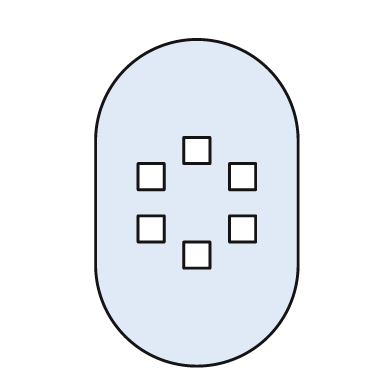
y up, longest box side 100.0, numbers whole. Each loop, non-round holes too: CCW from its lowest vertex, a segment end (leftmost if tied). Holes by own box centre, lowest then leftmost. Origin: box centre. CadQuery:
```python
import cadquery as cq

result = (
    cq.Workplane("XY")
    .moveTo(-31.0, -19.0)
    .threePointArc((0.0, -50.0), (31.0, -19.0))
    .lineTo(31.0, 19.0)
    .threePointArc((0.0, 50.0), (-31.0, 19.0))
    .close()
    .moveTo(-4.0, -20.0)
    .lineTo(4.0, -20.0)
    .lineTo(4.0, -12.0)
    .lineTo(-4.0, -12.0)
    .close()
    .moveTo(-18.0, -12.0)
    .lineTo(-10.0, -12.0)
    .lineTo(-10.0, -4.0)
    .lineTo(-18.0, -4.0)
    .close()
    .moveTo(10.0, -12.0)
    .lineTo(18.0, -12.0)
    .lineTo(18.0, -4.0)
    .lineTo(10.0, -4.0)
    .close()
    .moveTo(-18.0, 4.0)
    .lineTo(-10.0, 4.0)
    .lineTo(-10.0, 12.0)
    .lineTo(-18.0, 12.0)
    .close()
    .moveTo(10.0, 4.0)
    .lineTo(18.0, 4.0)
    .lineTo(18.0, 12.0)
    .lineTo(10.0, 12.0)
    .close()
    .moveTo(-4.0, 12.0)
    .lineTo(4.0, 12.0)
    .lineTo(4.0, 20.0)
    .lineTo(-4.0, 20.0)
    .close()
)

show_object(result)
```